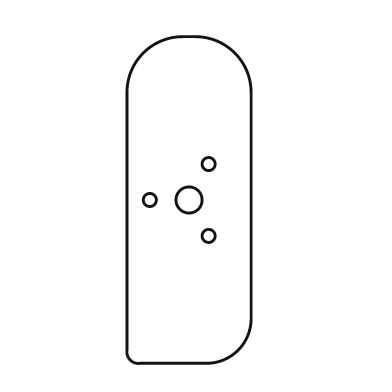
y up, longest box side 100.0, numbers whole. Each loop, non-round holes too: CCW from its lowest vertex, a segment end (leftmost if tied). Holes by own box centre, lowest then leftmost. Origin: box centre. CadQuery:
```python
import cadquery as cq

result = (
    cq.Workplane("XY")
    .moveTo(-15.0, -50.0)
    .lineTo(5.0, -50.0)
    .threePointArc((15.0, -46.0), (19.0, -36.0))
    .lineTo(19.0, 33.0)
    .threePointArc((14.0, 45.0), (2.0, 50.0))
    .lineTo(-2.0, 50.0)
    .threePointArc((-14.0, 45.0), (-19.0, 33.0))
    .lineTo(-19.0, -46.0)
    .threePointArc((-18.0, -49.0), (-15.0, -50.0))
    .close()
    .moveTo(6.0, -11.0)
    .circle(2.0)
    .moveTo(-12.0, 0.0)
    .circle(2.0)
    .moveTo(0.0, 0.0)
    .circle(4.0)
    .moveTo(6.0, 11.0)
    .circle(2.0)
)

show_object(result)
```